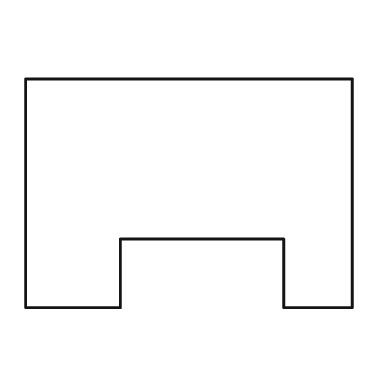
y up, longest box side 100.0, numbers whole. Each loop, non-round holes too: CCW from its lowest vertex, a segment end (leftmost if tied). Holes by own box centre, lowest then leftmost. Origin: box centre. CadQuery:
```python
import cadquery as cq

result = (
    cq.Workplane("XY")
    .moveTo(-50.0, -35.0)
    .lineTo(-21.0, -35.0)
    .lineTo(-21.0, -14.0)
    .lineTo(29.0, -14.0)
    .lineTo(29.0, -35.0)
    .lineTo(50.0, -35.0)
    .lineTo(50.0, 35.0)
    .lineTo(-50.0, 35.0)
    .close()
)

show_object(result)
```